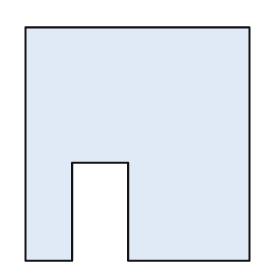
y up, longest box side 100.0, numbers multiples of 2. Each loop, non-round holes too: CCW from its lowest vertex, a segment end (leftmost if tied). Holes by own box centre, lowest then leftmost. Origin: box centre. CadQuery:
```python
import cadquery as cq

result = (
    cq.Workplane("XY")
    .moveTo(-48.0, -50.0)
    .lineTo(-28.0, -50.0)
    .lineTo(-28.0, -8.0)
    .lineTo(-4.0, -8.0)
    .lineTo(-4.0, -50.0)
    .lineTo(48.0, -50.0)
    .lineTo(48.0, 50.0)
    .lineTo(-48.0, 50.0)
    .close()
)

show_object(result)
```